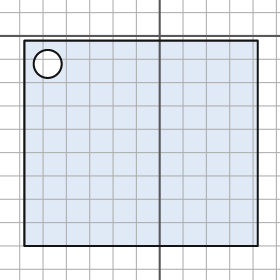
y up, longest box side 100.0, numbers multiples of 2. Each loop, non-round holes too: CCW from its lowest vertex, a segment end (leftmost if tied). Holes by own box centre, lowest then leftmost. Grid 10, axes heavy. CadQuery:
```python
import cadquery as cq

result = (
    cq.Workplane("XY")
    .moveTo(-58.0, -90.0)
    .lineTo(42.0, -90.0)
    .lineTo(42.0, -2.0)
    .lineTo(-58.0, -2.0)
    .close()
    .moveTo(-48.0, -12.0)
    .circle(6.0)
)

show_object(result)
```